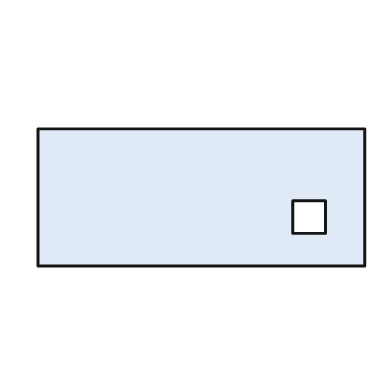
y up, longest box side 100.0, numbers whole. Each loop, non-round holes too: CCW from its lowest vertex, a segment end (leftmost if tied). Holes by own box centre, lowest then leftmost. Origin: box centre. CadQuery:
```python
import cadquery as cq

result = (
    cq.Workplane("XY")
    .moveTo(-50.0, -21.0)
    .lineTo(50.0, -21.0)
    .lineTo(50.0, 21.0)
    .lineTo(-50.0, 21.0)
    .close()
    .moveTo(28.0, -11.0)
    .lineTo(38.0, -11.0)
    .lineTo(38.0, -1.0)
    .lineTo(28.0, -1.0)
    .close()
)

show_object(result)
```